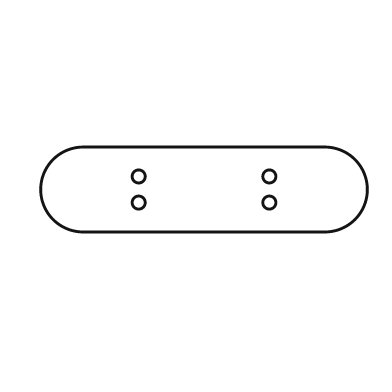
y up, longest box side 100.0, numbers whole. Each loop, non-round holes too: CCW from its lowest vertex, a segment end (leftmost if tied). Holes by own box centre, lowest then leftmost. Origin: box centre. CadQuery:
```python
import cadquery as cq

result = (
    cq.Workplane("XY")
    .moveTo(-37.0, -13.0)
    .lineTo(37.0, -13.0)
    .threePointArc((50.0, 0.0), (37.0, 13.0))
    .lineTo(-37.0, 13.0)
    .threePointArc((-50.0, 0.0), (-37.0, -13.0))
    .close()
    .moveTo(-20.0, -4.0)
    .circle(2.0)
    .moveTo(20.0, -4.0)
    .circle(2.0)
    .moveTo(-20.0, 4.0)
    .circle(2.0)
    .moveTo(20.0, 4.0)
    .circle(2.0)
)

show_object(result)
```